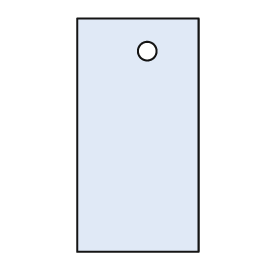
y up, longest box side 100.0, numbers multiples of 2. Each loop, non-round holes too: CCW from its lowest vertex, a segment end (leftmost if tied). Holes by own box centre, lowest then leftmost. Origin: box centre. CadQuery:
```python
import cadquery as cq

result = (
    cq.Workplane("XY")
    .moveTo(-26.0, -50.0)
    .lineTo(26.0, -50.0)
    .lineTo(26.0, 50.0)
    .lineTo(-26.0, 50.0)
    .close()
    .moveTo(4.0, 36.0)
    .circle(4.0)
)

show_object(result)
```